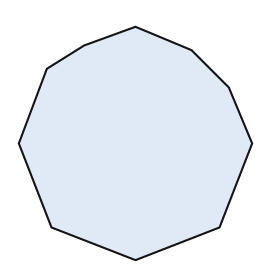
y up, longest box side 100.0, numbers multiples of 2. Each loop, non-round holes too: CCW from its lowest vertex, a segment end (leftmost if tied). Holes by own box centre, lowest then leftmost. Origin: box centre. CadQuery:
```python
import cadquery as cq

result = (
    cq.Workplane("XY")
    .moveTo(0.0, -50.0)
    .lineTo(36.0, -36.0)
    .lineTo(50.0, 0.0)
    .lineTo(40.0, 24.0)
    .lineTo(24.0, 40.0)
    .lineTo(0.0, 50.0)
    .lineTo(-22.0, 42.0)
    .lineTo(-38.0, 32.0)
    .lineTo(-50.0, 0.0)
    .lineTo(-36.0, -36.0)
    .close()
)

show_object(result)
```